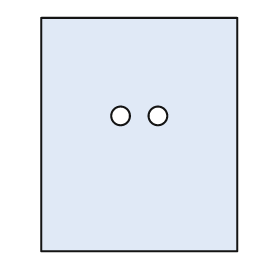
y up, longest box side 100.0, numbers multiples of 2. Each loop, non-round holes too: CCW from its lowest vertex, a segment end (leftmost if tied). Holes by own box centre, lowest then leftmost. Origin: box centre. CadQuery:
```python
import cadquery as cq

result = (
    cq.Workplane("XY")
    .moveTo(-42.0, -50.0)
    .lineTo(42.0, -50.0)
    .lineTo(42.0, 50.0)
    .lineTo(-42.0, 50.0)
    .close()
    .moveTo(-8.0, 8.0)
    .circle(4.0)
    .moveTo(8.0, 8.0)
    .circle(4.0)
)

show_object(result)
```